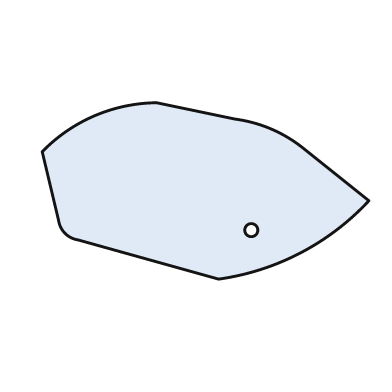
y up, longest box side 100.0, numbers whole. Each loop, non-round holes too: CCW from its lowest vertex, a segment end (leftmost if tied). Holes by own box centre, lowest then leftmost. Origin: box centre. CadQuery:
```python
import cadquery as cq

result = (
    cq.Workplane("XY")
    .moveTo(4.0, -27.0)
    .threePointArc((29.0, -19.0), (50.0, -3.0))
    .lineTo(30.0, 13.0)
    .threePointArc((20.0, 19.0), (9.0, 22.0))
    .lineTo(-15.0, 27.0)
    .threePointArc((-34.0, 23.0), (-50.0, 12.0))
    .lineTo(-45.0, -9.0)
    .threePointArc((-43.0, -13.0), (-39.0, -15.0))
    .close()
    .moveTo(14.0, -12.0)
    .circle(2.0)
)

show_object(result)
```